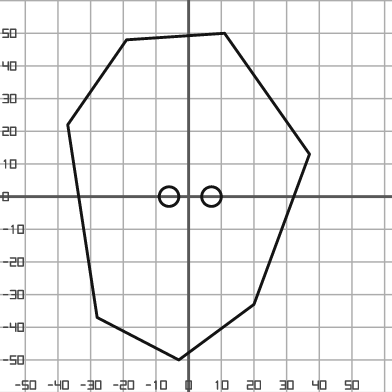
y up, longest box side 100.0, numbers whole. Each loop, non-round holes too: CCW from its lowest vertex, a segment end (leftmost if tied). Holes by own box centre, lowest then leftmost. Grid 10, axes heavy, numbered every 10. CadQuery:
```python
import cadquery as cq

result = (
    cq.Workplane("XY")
    .moveTo(-3.0, -50.0)
    .lineTo(20.0, -33.0)
    .lineTo(37.0, 13.0)
    .lineTo(11.0, 50.0)
    .lineTo(-19.0, 48.0)
    .lineTo(-37.0, 22.0)
    .lineTo(-28.0, -37.0)
    .close()
    .moveTo(-6.0, 0.0)
    .circle(3.0)
    .moveTo(7.0, 0.0)
    .circle(3.0)
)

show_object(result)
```